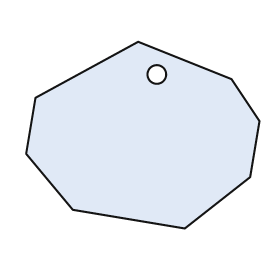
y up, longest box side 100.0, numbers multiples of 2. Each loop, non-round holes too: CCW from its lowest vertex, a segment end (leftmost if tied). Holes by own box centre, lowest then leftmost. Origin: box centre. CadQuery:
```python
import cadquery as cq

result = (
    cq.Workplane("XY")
    .moveTo(18.0, -40.0)
    .lineTo(46.0, -18.0)
    .lineTo(50.0, 6.0)
    .lineTo(38.0, 24.0)
    .lineTo(-2.0, 40.0)
    .lineTo(-46.0, 16.0)
    .lineTo(-50.0, -8.0)
    .lineTo(-30.0, -32.0)
    .close()
    .moveTo(6.0, 26.0)
    .circle(4.0)
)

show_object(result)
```